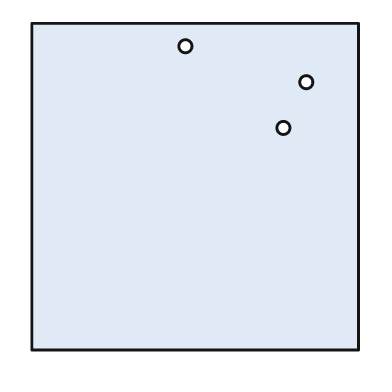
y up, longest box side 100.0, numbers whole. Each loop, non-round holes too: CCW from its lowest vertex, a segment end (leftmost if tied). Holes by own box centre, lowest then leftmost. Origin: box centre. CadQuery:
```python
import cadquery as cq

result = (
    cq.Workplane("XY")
    .moveTo(-50.0, -50.0)
    .lineTo(50.0, -50.0)
    .lineTo(50.0, 50.0)
    .lineTo(-50.0, 50.0)
    .close()
    .moveTo(27.0, 18.0)
    .circle(2.0)
    .moveTo(34.0, 32.0)
    .circle(2.0)
    .moveTo(-3.0, 43.0)
    .circle(2.0)
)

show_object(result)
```